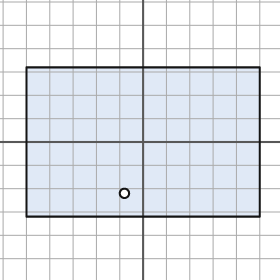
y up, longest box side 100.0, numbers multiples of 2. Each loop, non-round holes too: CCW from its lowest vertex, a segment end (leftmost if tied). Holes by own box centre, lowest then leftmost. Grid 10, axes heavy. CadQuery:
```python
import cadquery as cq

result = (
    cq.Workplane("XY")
    .moveTo(-50.0, -32.0)
    .lineTo(50.0, -32.0)
    .lineTo(50.0, 32.0)
    .lineTo(-50.0, 32.0)
    .close()
    .moveTo(-8.0, -22.0)
    .circle(2.0)
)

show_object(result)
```